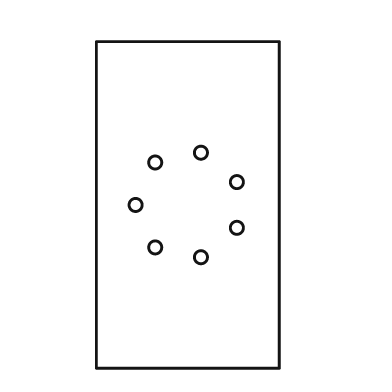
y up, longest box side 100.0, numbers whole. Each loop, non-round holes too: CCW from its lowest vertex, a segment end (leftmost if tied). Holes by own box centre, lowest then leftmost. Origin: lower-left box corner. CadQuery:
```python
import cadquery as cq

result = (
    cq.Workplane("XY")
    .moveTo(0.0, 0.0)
    .lineTo(56.0, 0.0)
    .lineTo(56.0, 100.0)
    .lineTo(0.0, 100.0)
    .close()
    .moveTo(32.0, 34.0)
    .circle(2.0)
    .moveTo(18.0, 37.0)
    .circle(2.0)
    .moveTo(43.0, 43.0)
    .circle(2.0)
    .moveTo(12.0, 50.0)
    .circle(2.0)
    .moveTo(43.0, 57.0)
    .circle(2.0)
    .moveTo(18.0, 63.0)
    .circle(2.0)
    .moveTo(32.0, 66.0)
    .circle(2.0)
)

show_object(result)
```